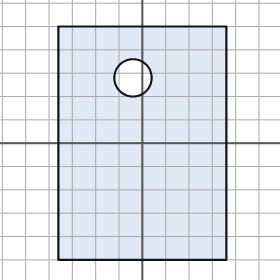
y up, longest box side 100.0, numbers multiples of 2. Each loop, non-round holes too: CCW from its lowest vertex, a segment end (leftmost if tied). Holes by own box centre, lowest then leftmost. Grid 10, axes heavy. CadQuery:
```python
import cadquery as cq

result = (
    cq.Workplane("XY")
    .moveTo(-36.0, -50.0)
    .lineTo(36.0, -50.0)
    .lineTo(36.0, 50.0)
    .lineTo(-36.0, 50.0)
    .close()
    .moveTo(-4.0, 28.0)
    .circle(8.0)
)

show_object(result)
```